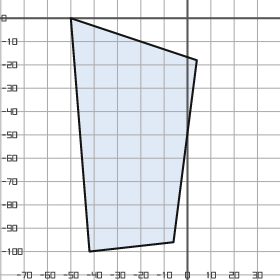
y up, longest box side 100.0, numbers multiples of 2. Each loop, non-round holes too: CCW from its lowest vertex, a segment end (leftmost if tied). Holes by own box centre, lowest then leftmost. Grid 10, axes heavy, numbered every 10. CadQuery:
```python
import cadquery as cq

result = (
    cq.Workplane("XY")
    .moveTo(-42.0, -100.0)
    .lineTo(-6.0, -96.0)
    .lineTo(4.0, -18.0)
    .lineTo(-50.0, 0.0)
    .close()
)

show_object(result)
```